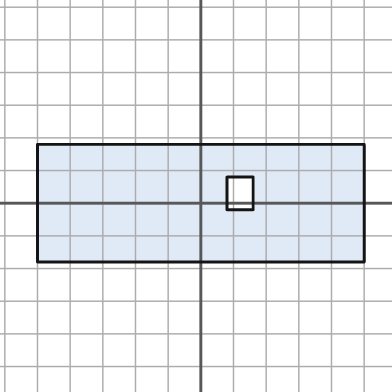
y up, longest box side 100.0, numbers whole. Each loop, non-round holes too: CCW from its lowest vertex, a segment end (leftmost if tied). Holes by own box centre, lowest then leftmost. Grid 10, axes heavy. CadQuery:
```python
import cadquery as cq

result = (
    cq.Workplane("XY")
    .moveTo(-50.0, -18.0)
    .lineTo(50.0, -18.0)
    .lineTo(50.0, 18.0)
    .lineTo(-50.0, 18.0)
    .close()
    .moveTo(8.0, -2.0)
    .lineTo(16.0, -2.0)
    .lineTo(16.0, 8.0)
    .lineTo(8.0, 8.0)
    .close()
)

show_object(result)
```